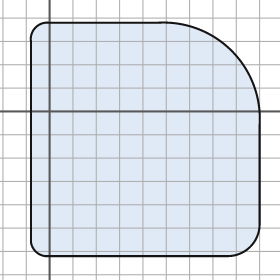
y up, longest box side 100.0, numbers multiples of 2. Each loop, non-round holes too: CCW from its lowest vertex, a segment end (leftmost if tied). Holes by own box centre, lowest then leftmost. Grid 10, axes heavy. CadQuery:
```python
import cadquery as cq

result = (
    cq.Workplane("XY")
    .moveTo(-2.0, -62.0)
    .lineTo(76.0, -62.0)
    .threePointArc((86.0, -58.0), (90.0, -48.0))
    .lineTo(90.0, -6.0)
    .threePointArc((78.0, 26.0), (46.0, 38.0))
    .lineTo(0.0, 38.0)
    .threePointArc((-6.0, 36.0), (-8.0, 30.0))
    .lineTo(-8.0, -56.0)
    .threePointArc((-6.0, -60.0), (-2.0, -62.0))
    .close()
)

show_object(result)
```